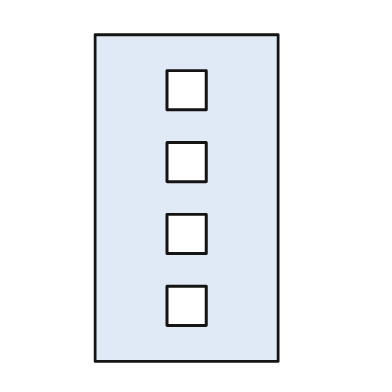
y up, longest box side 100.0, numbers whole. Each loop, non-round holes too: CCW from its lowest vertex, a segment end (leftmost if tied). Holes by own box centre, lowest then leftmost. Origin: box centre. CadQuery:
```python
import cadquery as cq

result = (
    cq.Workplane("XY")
    .moveTo(-28.0, -50.0)
    .lineTo(28.0, -50.0)
    .lineTo(28.0, 50.0)
    .lineTo(-28.0, 50.0)
    .close()
    .moveTo(-6.0, -39.0)
    .lineTo(6.0, -39.0)
    .lineTo(6.0, -27.0)
    .lineTo(-6.0, -27.0)
    .close()
    .moveTo(-6.0, -17.0)
    .lineTo(6.0, -17.0)
    .lineTo(6.0, -5.0)
    .lineTo(-6.0, -5.0)
    .close()
    .moveTo(-6.0, 5.0)
    .lineTo(6.0, 5.0)
    .lineTo(6.0, 17.0)
    .lineTo(-6.0, 17.0)
    .close()
    .moveTo(-6.0, 27.0)
    .lineTo(6.0, 27.0)
    .lineTo(6.0, 39.0)
    .lineTo(-6.0, 39.0)
    .close()
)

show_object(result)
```